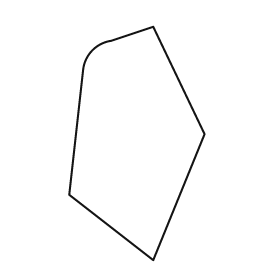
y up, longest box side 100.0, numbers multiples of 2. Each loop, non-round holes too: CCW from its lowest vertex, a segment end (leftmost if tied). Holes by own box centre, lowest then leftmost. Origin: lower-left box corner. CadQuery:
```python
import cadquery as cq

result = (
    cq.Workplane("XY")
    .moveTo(36.0, 0.0)
    .lineTo(58.0, 54.0)
    .lineTo(36.0, 100.0)
    .lineTo(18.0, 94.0)
    .threePointArc((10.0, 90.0), (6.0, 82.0))
    .lineTo(0.0, 28.0)
    .close()
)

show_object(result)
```